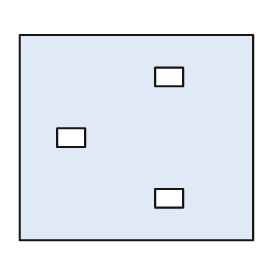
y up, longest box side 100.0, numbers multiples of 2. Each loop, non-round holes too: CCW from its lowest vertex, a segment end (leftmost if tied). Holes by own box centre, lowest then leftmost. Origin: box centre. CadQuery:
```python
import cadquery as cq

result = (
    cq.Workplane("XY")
    .moveTo(-50.0, -44.0)
    .lineTo(50.0, -44.0)
    .lineTo(50.0, 44.0)
    .lineTo(-50.0, 44.0)
    .close()
    .moveTo(8.0, -30.0)
    .lineTo(20.0, -30.0)
    .lineTo(20.0, -22.0)
    .lineTo(8.0, -22.0)
    .close()
    .moveTo(-34.0, -4.0)
    .lineTo(-22.0, -4.0)
    .lineTo(-22.0, 4.0)
    .lineTo(-34.0, 4.0)
    .close()
    .moveTo(8.0, 22.0)
    .lineTo(20.0, 22.0)
    .lineTo(20.0, 30.0)
    .lineTo(8.0, 30.0)
    .close()
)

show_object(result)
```